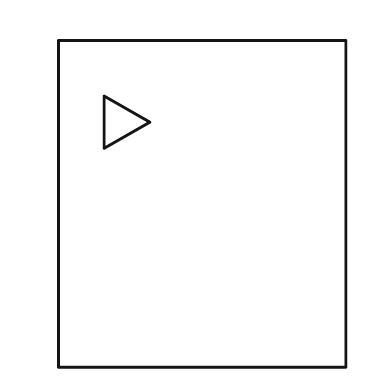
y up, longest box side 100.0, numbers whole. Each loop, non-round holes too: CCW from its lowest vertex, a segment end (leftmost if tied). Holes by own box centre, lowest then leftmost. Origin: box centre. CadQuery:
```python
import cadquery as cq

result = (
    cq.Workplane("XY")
    .moveTo(-44.0, -50.0)
    .lineTo(44.0, -50.0)
    .lineTo(44.0, 50.0)
    .lineTo(-44.0, 50.0)
    .close()
    .moveTo(-30.0, 17.0)
    .lineTo(-16.0, 25.0)
    .lineTo(-30.0, 33.0)
    .close()
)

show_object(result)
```